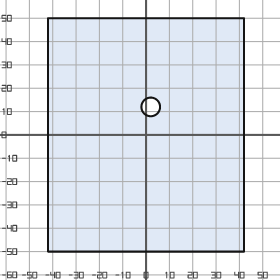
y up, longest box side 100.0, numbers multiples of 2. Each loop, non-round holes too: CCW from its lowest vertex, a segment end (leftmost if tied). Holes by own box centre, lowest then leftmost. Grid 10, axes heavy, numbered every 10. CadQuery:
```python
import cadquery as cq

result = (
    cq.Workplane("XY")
    .moveTo(-42.0, -50.0)
    .lineTo(42.0, -50.0)
    .lineTo(42.0, 50.0)
    .lineTo(-42.0, 50.0)
    .close()
    .moveTo(2.0, 12.0)
    .circle(4.0)
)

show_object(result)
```